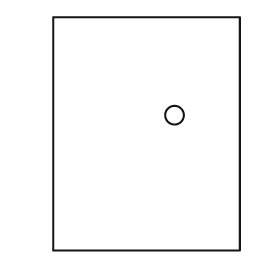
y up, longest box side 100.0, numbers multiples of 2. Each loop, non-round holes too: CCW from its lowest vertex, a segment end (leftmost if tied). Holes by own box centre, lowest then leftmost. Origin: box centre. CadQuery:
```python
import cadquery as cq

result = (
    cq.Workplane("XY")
    .moveTo(-40.0, -50.0)
    .lineTo(40.0, -50.0)
    .lineTo(40.0, 50.0)
    .lineTo(-40.0, 50.0)
    .close()
    .moveTo(12.0, 8.0)
    .circle(4.0)
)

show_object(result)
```